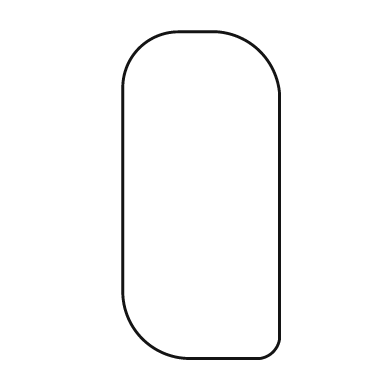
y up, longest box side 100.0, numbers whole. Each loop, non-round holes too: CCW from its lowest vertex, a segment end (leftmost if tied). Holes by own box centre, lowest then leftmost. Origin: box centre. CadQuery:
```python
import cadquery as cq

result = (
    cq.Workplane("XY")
    .moveTo(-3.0, -50.0)
    .lineTo(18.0, -50.0)
    .threePointArc((22.0, -48.0), (24.0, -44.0))
    .lineTo(24.0, 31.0)
    .threePointArc((18.0, 44.0), (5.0, 50.0))
    .lineTo(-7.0, 50.0)
    .threePointArc((-19.0, 45.0), (-24.0, 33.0))
    .lineTo(-24.0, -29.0)
    .threePointArc((-18.0, -44.0), (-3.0, -50.0))
    .close()
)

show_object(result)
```